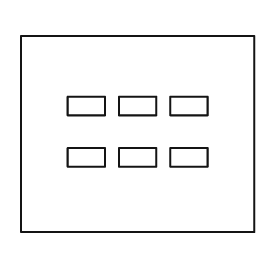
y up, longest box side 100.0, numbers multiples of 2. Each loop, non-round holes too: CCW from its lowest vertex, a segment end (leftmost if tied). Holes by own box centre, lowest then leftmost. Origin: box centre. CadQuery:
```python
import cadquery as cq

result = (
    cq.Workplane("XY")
    .moveTo(-50.0, -42.0)
    .lineTo(50.0, -42.0)
    .lineTo(50.0, 42.0)
    .lineTo(-50.0, 42.0)
    .close()
    .moveTo(-30.0, -14.0)
    .lineTo(-14.0, -14.0)
    .lineTo(-14.0, -6.0)
    .lineTo(-30.0, -6.0)
    .close()
    .moveTo(-8.0, -14.0)
    .lineTo(8.0, -14.0)
    .lineTo(8.0, -6.0)
    .lineTo(-8.0, -6.0)
    .close()
    .moveTo(14.0, -14.0)
    .lineTo(30.0, -14.0)
    .lineTo(30.0, -6.0)
    .lineTo(14.0, -6.0)
    .close()
    .moveTo(-30.0, 8.0)
    .lineTo(-14.0, 8.0)
    .lineTo(-14.0, 16.0)
    .lineTo(-30.0, 16.0)
    .close()
    .moveTo(-8.0, 8.0)
    .lineTo(8.0, 8.0)
    .lineTo(8.0, 16.0)
    .lineTo(-8.0, 16.0)
    .close()
    .moveTo(14.0, 8.0)
    .lineTo(30.0, 8.0)
    .lineTo(30.0, 16.0)
    .lineTo(14.0, 16.0)
    .close()
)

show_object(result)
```